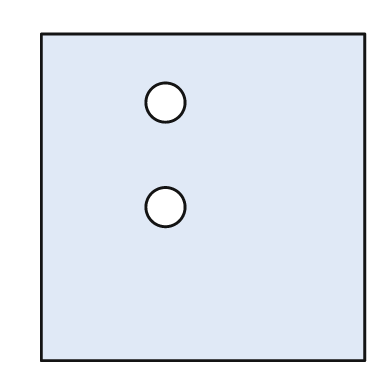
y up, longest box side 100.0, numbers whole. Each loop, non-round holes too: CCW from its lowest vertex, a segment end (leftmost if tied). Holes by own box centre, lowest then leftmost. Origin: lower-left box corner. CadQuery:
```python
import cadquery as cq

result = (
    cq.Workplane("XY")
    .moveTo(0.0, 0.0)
    .lineTo(99.0, 0.0)
    .lineTo(99.0, 100.0)
    .lineTo(0.0, 100.0)
    .close()
    .moveTo(38.0, 47.0)
    .circle(6.0)
    .moveTo(38.0, 79.0)
    .circle(6.0)
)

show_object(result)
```